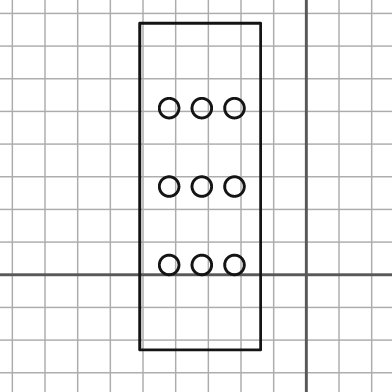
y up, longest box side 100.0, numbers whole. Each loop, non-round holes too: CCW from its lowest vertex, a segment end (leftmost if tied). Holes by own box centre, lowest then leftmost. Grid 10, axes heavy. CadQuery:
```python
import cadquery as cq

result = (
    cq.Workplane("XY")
    .moveTo(-51.0, -23.0)
    .lineTo(-14.0, -23.0)
    .lineTo(-14.0, 77.0)
    .lineTo(-51.0, 77.0)
    .close()
    .moveTo(-42.0, 3.0)
    .circle(3.0)
    .moveTo(-32.0, 3.0)
    .circle(3.0)
    .moveTo(-22.0, 3.0)
    .circle(3.0)
    .moveTo(-42.0, 27.0)
    .circle(3.0)
    .moveTo(-32.0, 27.0)
    .circle(3.0)
    .moveTo(-22.0, 27.0)
    .circle(3.0)
    .moveTo(-42.0, 51.0)
    .circle(3.0)
    .moveTo(-32.0, 51.0)
    .circle(3.0)
    .moveTo(-22.0, 51.0)
    .circle(3.0)
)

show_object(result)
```